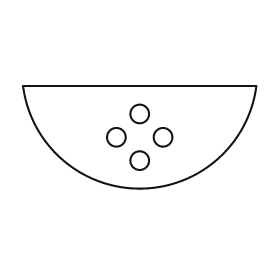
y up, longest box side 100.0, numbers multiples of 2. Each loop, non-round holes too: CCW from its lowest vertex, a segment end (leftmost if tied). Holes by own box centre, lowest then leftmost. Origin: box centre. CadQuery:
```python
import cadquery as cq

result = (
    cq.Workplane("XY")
    .moveTo(-50.0, 22.0)
    .threePointArc((0.0, -22.0), (50.0, 22.0))
    .close()
    .moveTo(0.0, -10.0)
    .circle(4.0)
    .moveTo(-10.0, 0.0)
    .circle(4.0)
    .moveTo(10.0, 0.0)
    .circle(4.0)
    .moveTo(0.0, 10.0)
    .circle(4.0)
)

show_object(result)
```